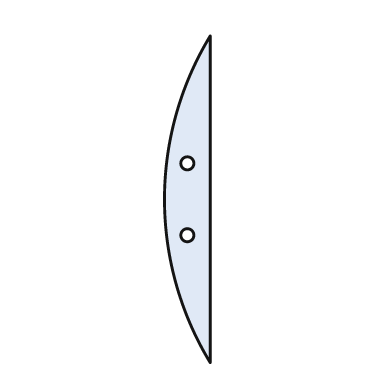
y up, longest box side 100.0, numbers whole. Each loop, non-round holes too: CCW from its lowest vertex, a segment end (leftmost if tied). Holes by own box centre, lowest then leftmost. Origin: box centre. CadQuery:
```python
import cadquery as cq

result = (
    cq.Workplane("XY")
    .moveTo(7.0, -50.0)
    .lineTo(7.0, 50.0)
    .threePointArc((-7.0, 0.0), (7.0, -50.0))
    .close()
    .moveTo(0.0, -11.0)
    .circle(2.0)
    .moveTo(0.0, 11.0)
    .circle(2.0)
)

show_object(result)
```